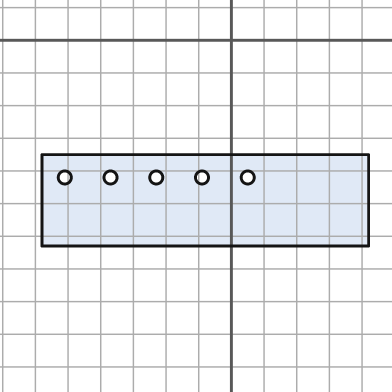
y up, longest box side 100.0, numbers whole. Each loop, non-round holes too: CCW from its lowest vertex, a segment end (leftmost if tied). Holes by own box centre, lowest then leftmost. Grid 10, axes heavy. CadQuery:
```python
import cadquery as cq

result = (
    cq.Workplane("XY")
    .moveTo(-58.0, -63.0)
    .lineTo(42.0, -63.0)
    .lineTo(42.0, -35.0)
    .lineTo(-58.0, -35.0)
    .close()
    .moveTo(-51.0, -42.0)
    .circle(2.0)
    .moveTo(-37.0, -42.0)
    .circle(2.0)
    .moveTo(-23.0, -42.0)
    .circle(2.0)
    .moveTo(-9.0, -42.0)
    .circle(2.0)
    .moveTo(5.0, -42.0)
    .circle(2.0)
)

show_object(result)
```